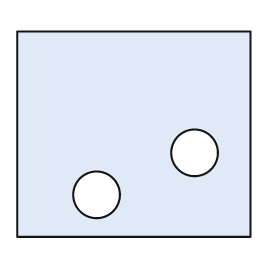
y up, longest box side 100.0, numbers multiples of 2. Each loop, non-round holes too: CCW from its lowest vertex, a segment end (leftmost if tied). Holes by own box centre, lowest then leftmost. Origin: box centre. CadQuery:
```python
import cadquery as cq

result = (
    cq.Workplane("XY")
    .moveTo(-50.0, -44.0)
    .lineTo(50.0, -44.0)
    .lineTo(50.0, 44.0)
    .lineTo(-50.0, 44.0)
    .close()
    .moveTo(-16.0, -26.0)
    .circle(10.0)
    .moveTo(26.0, -8.0)
    .circle(10.0)
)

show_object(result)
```